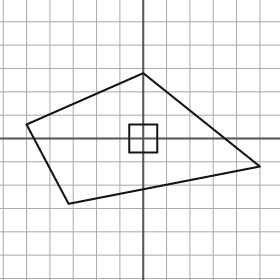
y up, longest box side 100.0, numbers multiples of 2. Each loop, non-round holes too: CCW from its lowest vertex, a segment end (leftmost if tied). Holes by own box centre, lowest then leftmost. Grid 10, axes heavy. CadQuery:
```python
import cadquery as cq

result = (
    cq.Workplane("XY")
    .moveTo(-32.0, -28.0)
    .lineTo(50.0, -12.0)
    .lineTo(0.0, 28.0)
    .lineTo(-50.0, 6.0)
    .close()
    .moveTo(-6.0, -6.0)
    .lineTo(6.0, -6.0)
    .lineTo(6.0, 6.0)
    .lineTo(-6.0, 6.0)
    .close()
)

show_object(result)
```